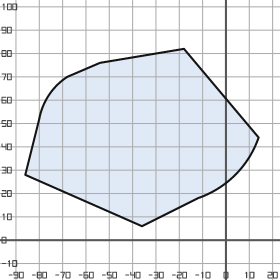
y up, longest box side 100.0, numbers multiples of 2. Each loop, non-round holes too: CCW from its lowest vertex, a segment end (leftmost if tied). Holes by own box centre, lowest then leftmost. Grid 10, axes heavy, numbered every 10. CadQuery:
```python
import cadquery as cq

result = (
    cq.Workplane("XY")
    .moveTo(-36.0, 6.0)
    .lineTo(-12.0, 18.0)
    .threePointArc((4.0, 28.0), (14.0, 44.0))
    .lineTo(-18.0, 82.0)
    .lineTo(-54.0, 76.0)
    .lineTo(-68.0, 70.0)
    .threePointArc((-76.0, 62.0), (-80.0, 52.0))
    .lineTo(-86.0, 28.0)
    .close()
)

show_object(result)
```